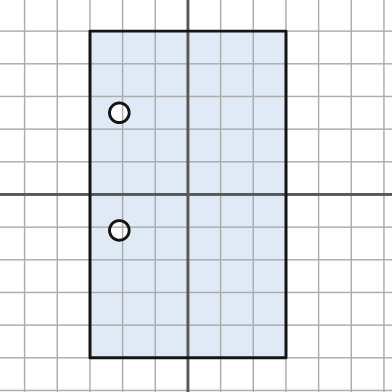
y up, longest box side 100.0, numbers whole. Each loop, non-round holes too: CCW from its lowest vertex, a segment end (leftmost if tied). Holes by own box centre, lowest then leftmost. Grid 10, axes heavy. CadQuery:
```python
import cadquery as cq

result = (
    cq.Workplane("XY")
    .moveTo(-30.0, -50.0)
    .lineTo(30.0, -50.0)
    .lineTo(30.0, 50.0)
    .lineTo(-30.0, 50.0)
    .close()
    .moveTo(-21.0, -11.0)
    .circle(3.0)
    .moveTo(-21.0, 25.0)
    .circle(3.0)
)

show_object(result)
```